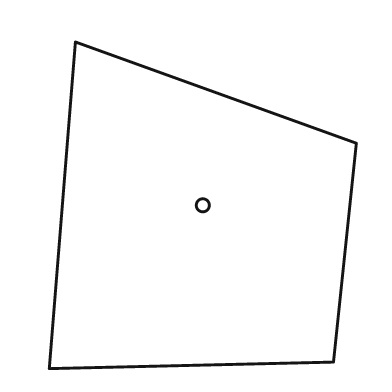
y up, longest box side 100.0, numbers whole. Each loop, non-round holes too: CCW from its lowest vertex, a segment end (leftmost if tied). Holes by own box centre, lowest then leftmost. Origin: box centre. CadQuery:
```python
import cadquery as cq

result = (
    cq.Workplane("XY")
    .moveTo(-47.0, -50.0)
    .lineTo(40.0, -48.0)
    .lineTo(47.0, 19.0)
    .lineTo(-39.0, 50.0)
    .close()
    .moveTo(0.0, 0.0)
    .circle(2.0)
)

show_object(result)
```